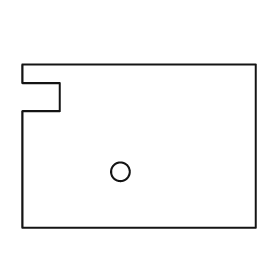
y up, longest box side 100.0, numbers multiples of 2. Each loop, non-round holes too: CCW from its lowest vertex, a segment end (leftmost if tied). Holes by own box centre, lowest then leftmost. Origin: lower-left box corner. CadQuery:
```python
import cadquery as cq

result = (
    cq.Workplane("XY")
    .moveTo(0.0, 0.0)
    .lineTo(100.0, 0.0)
    .lineTo(100.0, 70.0)
    .lineTo(0.0, 70.0)
    .lineTo(0.0, 62.0)
    .lineTo(16.0, 62.0)
    .lineTo(16.0, 50.0)
    .lineTo(0.0, 50.0)
    .close()
    .moveTo(42.0, 24.0)
    .circle(4.0)
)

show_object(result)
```